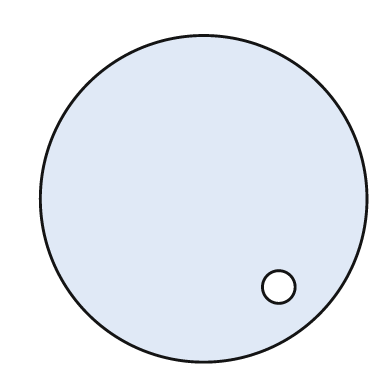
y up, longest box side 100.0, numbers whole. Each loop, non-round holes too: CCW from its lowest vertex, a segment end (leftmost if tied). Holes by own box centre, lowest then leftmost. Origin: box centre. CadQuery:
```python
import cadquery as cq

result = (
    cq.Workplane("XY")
    .moveTo(0.0, 0.0)
    .circle(50.0)
    .moveTo(23.0, -27.0)
    .circle(5.0)
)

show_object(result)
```